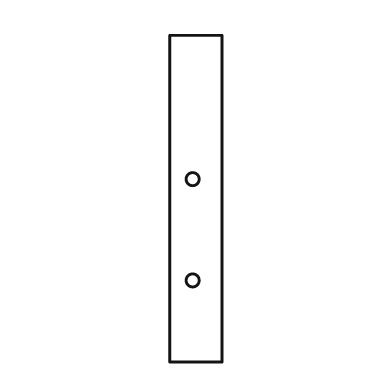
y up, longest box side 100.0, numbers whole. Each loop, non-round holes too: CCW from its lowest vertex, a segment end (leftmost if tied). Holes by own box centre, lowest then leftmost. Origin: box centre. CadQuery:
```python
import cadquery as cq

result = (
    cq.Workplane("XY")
    .moveTo(-8.0, -50.0)
    .lineTo(8.0, -50.0)
    .lineTo(8.0, 50.0)
    .lineTo(-8.0, 50.0)
    .close()
    .moveTo(-1.0, -25.0)
    .circle(2.0)
    .moveTo(-1.0, 6.0)
    .circle(2.0)
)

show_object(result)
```